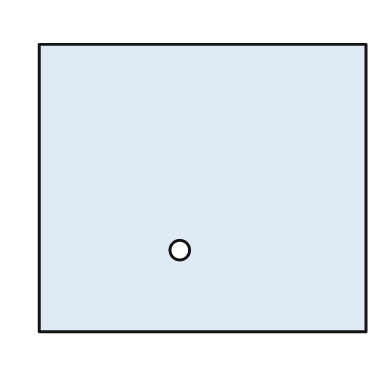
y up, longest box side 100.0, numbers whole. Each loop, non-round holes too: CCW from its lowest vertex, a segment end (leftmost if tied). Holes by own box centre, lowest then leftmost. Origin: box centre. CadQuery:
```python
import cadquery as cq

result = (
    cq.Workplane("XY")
    .moveTo(-50.0, -44.0)
    .lineTo(50.0, -44.0)
    .lineTo(50.0, 44.0)
    .lineTo(-50.0, 44.0)
    .close()
    .moveTo(-7.0, -19.0)
    .circle(3.0)
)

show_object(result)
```